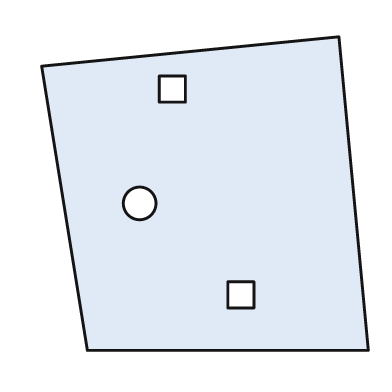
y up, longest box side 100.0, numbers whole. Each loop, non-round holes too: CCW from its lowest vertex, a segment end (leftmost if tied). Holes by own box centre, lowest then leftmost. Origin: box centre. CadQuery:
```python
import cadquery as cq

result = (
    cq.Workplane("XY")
    .moveTo(-36.0, -48.0)
    .lineTo(50.0, -48.0)
    .lineTo(41.0, 48.0)
    .lineTo(-50.0, 39.0)
    .close()
    .moveTo(7.0, -35.0)
    .lineTo(15.0, -35.0)
    .lineTo(15.0, -27.0)
    .lineTo(7.0, -27.0)
    .close()
    .moveTo(-20.0, -3.0)
    .circle(5.0)
    .moveTo(-14.0, 28.0)
    .lineTo(-6.0, 28.0)
    .lineTo(-6.0, 36.0)
    .lineTo(-14.0, 36.0)
    .close()
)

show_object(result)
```